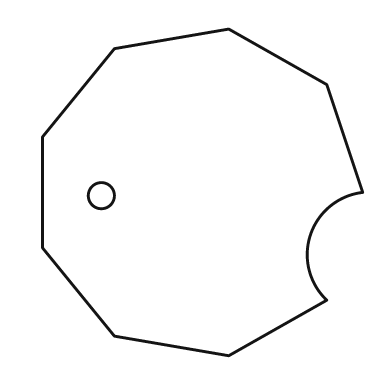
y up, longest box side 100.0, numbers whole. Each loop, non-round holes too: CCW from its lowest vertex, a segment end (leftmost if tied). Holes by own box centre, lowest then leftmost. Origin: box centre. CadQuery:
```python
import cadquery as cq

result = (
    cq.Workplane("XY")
    .moveTo(8.0, -50.0)
    .lineTo(38.0, -33.0)
    .threePointArc((33.0, -13.0), (49.0, 0.0))
    .lineTo(38.0, 33.0)
    .lineTo(8.0, 50.0)
    .lineTo(-27.0, 44.0)
    .lineTo(-49.0, 17.0)
    .lineTo(-49.0, -17.0)
    .lineTo(-27.0, -44.0)
    .close()
    .moveTo(-31.0, -1.0)
    .circle(4.0)
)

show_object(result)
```